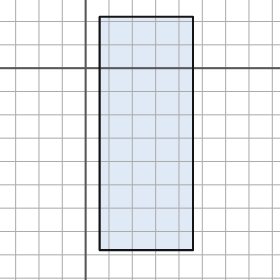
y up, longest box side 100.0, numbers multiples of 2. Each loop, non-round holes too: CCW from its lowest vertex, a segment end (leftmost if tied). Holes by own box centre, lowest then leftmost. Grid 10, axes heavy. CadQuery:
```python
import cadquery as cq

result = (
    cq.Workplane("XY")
    .moveTo(6.0, -78.0)
    .lineTo(46.0, -78.0)
    .lineTo(46.0, 22.0)
    .lineTo(6.0, 22.0)
    .close()
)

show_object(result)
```